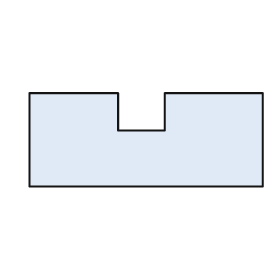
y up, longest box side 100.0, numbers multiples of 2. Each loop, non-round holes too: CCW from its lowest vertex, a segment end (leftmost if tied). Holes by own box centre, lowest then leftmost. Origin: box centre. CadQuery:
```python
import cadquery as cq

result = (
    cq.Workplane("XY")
    .moveTo(-50.0, -20.0)
    .lineTo(50.0, -20.0)
    .lineTo(50.0, 20.0)
    .lineTo(8.0, 20.0)
    .lineTo(8.0, 4.0)
    .lineTo(-12.0, 4.0)
    .lineTo(-12.0, 20.0)
    .lineTo(-50.0, 20.0)
    .close()
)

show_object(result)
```